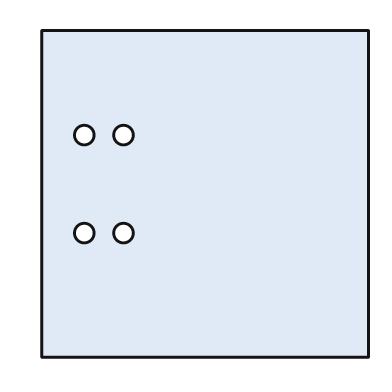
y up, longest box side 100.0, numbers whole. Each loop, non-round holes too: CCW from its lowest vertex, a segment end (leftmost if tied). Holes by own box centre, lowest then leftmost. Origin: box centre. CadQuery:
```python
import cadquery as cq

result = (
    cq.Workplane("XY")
    .moveTo(-50.0, -50.0)
    .lineTo(50.0, -50.0)
    .lineTo(50.0, 50.0)
    .lineTo(-50.0, 50.0)
    .close()
    .moveTo(-37.0, -12.0)
    .circle(3.0)
    .moveTo(-25.0, -12.0)
    .circle(3.0)
    .moveTo(-37.0, 18.0)
    .circle(3.0)
    .moveTo(-25.0, 18.0)
    .circle(3.0)
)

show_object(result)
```